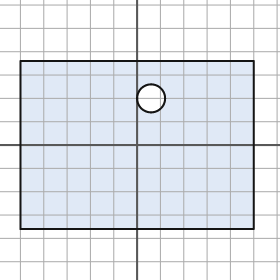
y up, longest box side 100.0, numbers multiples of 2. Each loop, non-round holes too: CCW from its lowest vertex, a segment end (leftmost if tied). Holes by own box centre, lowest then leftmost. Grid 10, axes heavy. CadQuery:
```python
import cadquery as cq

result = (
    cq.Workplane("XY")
    .moveTo(-50.0, -36.0)
    .lineTo(50.0, -36.0)
    .lineTo(50.0, 36.0)
    .lineTo(-50.0, 36.0)
    .close()
    .moveTo(6.0, 20.0)
    .circle(6.0)
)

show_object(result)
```